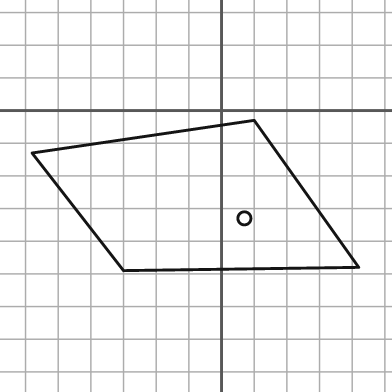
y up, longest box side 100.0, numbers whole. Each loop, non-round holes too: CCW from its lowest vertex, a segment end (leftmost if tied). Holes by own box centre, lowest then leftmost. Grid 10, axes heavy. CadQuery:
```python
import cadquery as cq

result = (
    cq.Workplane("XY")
    .moveTo(-30.0, -49.0)
    .lineTo(42.0, -48.0)
    .lineTo(10.0, -3.0)
    .lineTo(-58.0, -13.0)
    .close()
    .moveTo(7.0, -33.0)
    .circle(2.0)
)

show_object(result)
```